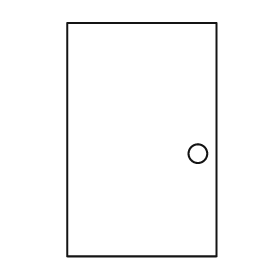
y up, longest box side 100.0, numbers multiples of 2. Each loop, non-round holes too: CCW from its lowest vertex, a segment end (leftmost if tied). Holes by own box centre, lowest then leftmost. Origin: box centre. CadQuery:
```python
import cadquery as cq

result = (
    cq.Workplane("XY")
    .moveTo(-32.0, -50.0)
    .lineTo(32.0, -50.0)
    .lineTo(32.0, 50.0)
    .lineTo(-32.0, 50.0)
    .close()
    .moveTo(24.0, -6.0)
    .circle(4.0)
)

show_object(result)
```